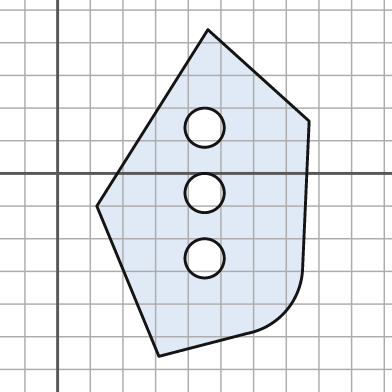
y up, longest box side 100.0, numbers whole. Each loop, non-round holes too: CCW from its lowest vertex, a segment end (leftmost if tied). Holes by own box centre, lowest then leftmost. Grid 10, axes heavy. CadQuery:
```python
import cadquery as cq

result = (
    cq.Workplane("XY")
    .moveTo(31.0, -56.0)
    .lineTo(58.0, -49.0)
    .threePointArc((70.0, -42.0), (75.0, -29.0))
    .lineTo(77.0, 16.0)
    .lineTo(46.0, 44.0)
    .lineTo(12.0, -10.0)
    .close()
    .moveTo(45.0, -26.0)
    .circle(6.0)
    .moveTo(45.0, -6.0)
    .circle(6.0)
    .moveTo(45.0, 14.0)
    .circle(6.0)
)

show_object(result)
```